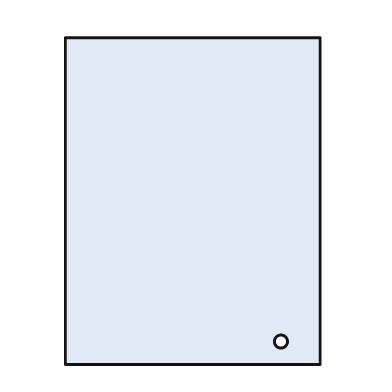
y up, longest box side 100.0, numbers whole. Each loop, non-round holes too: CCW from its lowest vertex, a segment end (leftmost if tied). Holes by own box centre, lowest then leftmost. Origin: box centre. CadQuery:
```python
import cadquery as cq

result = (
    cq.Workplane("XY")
    .moveTo(-39.0, -50.0)
    .lineTo(39.0, -50.0)
    .lineTo(39.0, 50.0)
    .lineTo(-39.0, 50.0)
    .close()
    .moveTo(27.0, -43.0)
    .circle(2.0)
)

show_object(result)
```